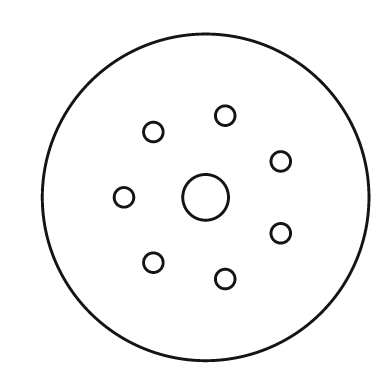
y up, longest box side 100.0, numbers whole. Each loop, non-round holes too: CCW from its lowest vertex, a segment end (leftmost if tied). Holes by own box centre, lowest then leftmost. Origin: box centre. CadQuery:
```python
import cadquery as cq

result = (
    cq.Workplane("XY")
    .moveTo(0.0, 0.0)
    .circle(50.0)
    .moveTo(6.0, -25.0)
    .circle(3.0)
    .moveTo(-16.0, -20.0)
    .circle(3.0)
    .moveTo(23.0, -11.0)
    .circle(3.0)
    .moveTo(-25.0, 0.0)
    .circle(3.0)
    .moveTo(0.0, 0.0)
    .circle(7.0)
    .moveTo(23.0, 11.0)
    .circle(3.0)
    .moveTo(-16.0, 20.0)
    .circle(3.0)
    .moveTo(6.0, 25.0)
    .circle(3.0)
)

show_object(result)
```